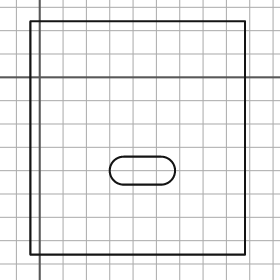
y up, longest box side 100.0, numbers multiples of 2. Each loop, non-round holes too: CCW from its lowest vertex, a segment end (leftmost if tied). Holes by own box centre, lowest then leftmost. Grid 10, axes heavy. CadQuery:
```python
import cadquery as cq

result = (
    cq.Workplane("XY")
    .moveTo(-4.0, -76.0)
    .lineTo(88.0, -76.0)
    .lineTo(88.0, 24.0)
    .lineTo(-4.0, 24.0)
    .close()
    .moveTo(36.0, -46.0)
    .lineTo(52.0, -46.0)
    .threePointArc((58.0, -40.0), (52.0, -34.0))
    .lineTo(36.0, -34.0)
    .threePointArc((30.0, -40.0), (36.0, -46.0))
    .close()
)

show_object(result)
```